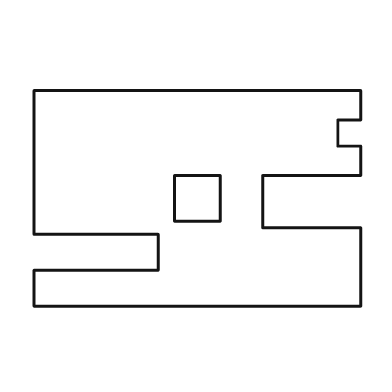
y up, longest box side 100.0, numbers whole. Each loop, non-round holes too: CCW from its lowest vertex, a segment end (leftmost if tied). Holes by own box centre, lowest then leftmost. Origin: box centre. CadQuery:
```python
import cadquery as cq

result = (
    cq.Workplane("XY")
    .moveTo(-50.0, -33.0)
    .lineTo(50.0, -33.0)
    .lineTo(50.0, -9.0)
    .lineTo(20.0, -9.0)
    .lineTo(20.0, 7.0)
    .lineTo(50.0, 7.0)
    .lineTo(50.0, 16.0)
    .lineTo(43.0, 16.0)
    .lineTo(43.0, 24.0)
    .lineTo(50.0, 24.0)
    .lineTo(50.0, 33.0)
    .lineTo(-50.0, 33.0)
    .lineTo(-50.0, -11.0)
    .lineTo(-12.0, -11.0)
    .lineTo(-12.0, -22.0)
    .lineTo(-50.0, -22.0)
    .close()
    .moveTo(-7.0, -7.0)
    .lineTo(7.0, -7.0)
    .lineTo(7.0, 7.0)
    .lineTo(-7.0, 7.0)
    .close()
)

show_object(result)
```